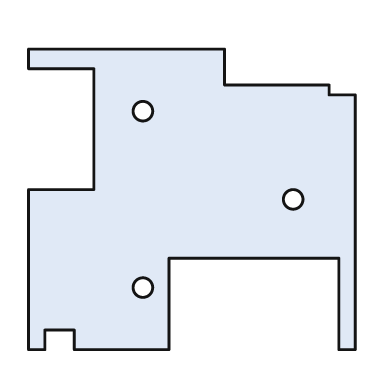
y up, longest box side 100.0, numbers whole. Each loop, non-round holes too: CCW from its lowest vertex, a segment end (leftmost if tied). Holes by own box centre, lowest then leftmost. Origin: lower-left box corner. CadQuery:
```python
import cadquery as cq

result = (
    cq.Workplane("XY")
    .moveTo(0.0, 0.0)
    .lineTo(5.0, 0.0)
    .lineTo(5.0, 6.0)
    .lineTo(14.0, 6.0)
    .lineTo(14.0, 0.0)
    .lineTo(43.0, 0.0)
    .lineTo(43.0, 28.0)
    .lineTo(95.0, 28.0)
    .lineTo(95.0, 0.0)
    .lineTo(100.0, 0.0)
    .lineTo(100.0, 78.0)
    .lineTo(92.0, 78.0)
    .lineTo(92.0, 81.0)
    .lineTo(60.0, 81.0)
    .lineTo(60.0, 92.0)
    .lineTo(0.0, 92.0)
    .lineTo(0.0, 86.0)
    .lineTo(20.0, 86.0)
    .lineTo(20.0, 49.0)
    .lineTo(0.0, 49.0)
    .close()
    .moveTo(35.0, 19.0)
    .circle(3.0)
    .moveTo(81.0, 46.0)
    .circle(3.0)
    .moveTo(35.0, 73.0)
    .circle(3.0)
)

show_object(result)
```